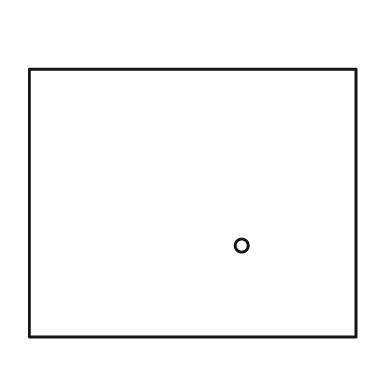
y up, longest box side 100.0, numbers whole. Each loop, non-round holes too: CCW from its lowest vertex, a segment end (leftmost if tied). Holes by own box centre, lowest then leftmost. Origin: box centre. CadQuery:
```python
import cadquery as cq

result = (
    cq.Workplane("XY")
    .moveTo(-50.0, -41.0)
    .lineTo(50.0, -41.0)
    .lineTo(50.0, 41.0)
    .lineTo(-50.0, 41.0)
    .close()
    .moveTo(15.0, -13.0)
    .circle(2.0)
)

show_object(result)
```